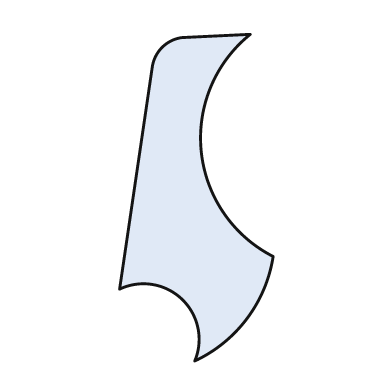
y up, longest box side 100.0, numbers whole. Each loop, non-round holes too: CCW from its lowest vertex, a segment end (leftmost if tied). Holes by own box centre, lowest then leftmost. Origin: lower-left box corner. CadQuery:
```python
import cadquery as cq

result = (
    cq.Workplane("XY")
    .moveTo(23.0, 0.0)
    .threePointArc((39.0, 13.0), (47.0, 32.0))
    .threePointArc((25.0, 64.0), (40.0, 100.0))
    .lineTo(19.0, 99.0)
    .threePointArc((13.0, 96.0), (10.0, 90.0))
    .lineTo(0.0, 22.0)
    .threePointArc((19.0, 19.0), (23.0, 0.0))
    .close()
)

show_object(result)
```